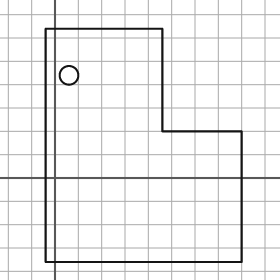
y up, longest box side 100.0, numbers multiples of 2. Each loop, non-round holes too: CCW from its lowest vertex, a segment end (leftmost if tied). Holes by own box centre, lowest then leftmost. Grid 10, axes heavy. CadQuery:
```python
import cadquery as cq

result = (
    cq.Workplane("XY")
    .moveTo(-4.0, -36.0)
    .lineTo(80.0, -36.0)
    .lineTo(80.0, 20.0)
    .lineTo(46.0, 20.0)
    .lineTo(46.0, 64.0)
    .lineTo(-4.0, 64.0)
    .close()
    .moveTo(6.0, 44.0)
    .circle(4.0)
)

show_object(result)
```